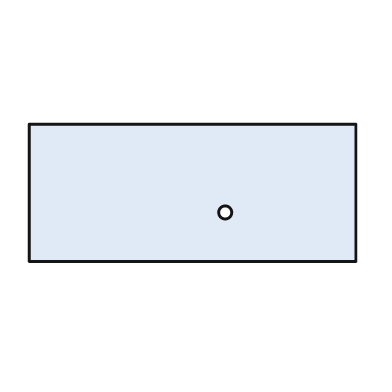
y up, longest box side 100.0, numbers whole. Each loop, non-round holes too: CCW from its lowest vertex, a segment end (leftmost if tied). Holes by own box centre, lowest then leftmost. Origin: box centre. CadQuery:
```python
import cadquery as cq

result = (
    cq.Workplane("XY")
    .moveTo(-50.0, -21.0)
    .lineTo(50.0, -21.0)
    .lineTo(50.0, 21.0)
    .lineTo(-50.0, 21.0)
    .close()
    .moveTo(10.0, -6.0)
    .circle(2.0)
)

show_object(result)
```